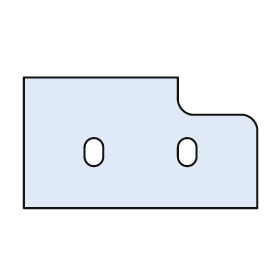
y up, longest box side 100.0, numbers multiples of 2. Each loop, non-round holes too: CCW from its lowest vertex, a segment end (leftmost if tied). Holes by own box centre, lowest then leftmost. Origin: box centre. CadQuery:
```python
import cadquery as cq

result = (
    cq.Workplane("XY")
    .moveTo(-50.0, -28.0)
    .lineTo(50.0, -28.0)
    .lineTo(50.0, 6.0)
    .threePointArc((48.0, 10.0), (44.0, 12.0))
    .lineTo(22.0, 12.0)
    .threePointArc((18.0, 14.0), (16.0, 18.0))
    .lineTo(16.0, 28.0)
    .lineTo(-50.0, 28.0)
    .close()
    .moveTo(-24.0, -6.0)
    .threePointArc((-20.0, -10.0), (-16.0, -6.0))
    .lineTo(-16.0, -2.0)
    .threePointArc((-20.0, 2.0), (-24.0, -2.0))
    .close()
    .moveTo(16.0, -6.0)
    .threePointArc((20.0, -10.0), (24.0, -6.0))
    .lineTo(24.0, -2.0)
    .threePointArc((20.0, 2.0), (16.0, -2.0))
    .close()
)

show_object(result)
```